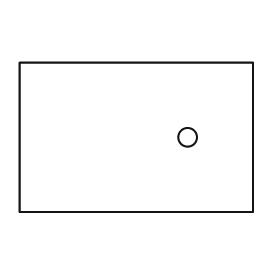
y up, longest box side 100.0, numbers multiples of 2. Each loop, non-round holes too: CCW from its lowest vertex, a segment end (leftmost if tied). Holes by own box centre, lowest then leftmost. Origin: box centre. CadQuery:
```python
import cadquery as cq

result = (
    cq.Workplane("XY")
    .moveTo(-50.0, -32.0)
    .lineTo(50.0, -32.0)
    .lineTo(50.0, 32.0)
    .lineTo(-50.0, 32.0)
    .close()
    .moveTo(22.0, 0.0)
    .circle(4.0)
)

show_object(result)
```